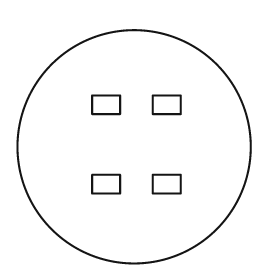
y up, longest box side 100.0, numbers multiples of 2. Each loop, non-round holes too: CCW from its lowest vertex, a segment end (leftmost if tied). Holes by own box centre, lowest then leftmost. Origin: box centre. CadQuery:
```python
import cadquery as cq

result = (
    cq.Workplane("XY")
    .moveTo(0.0, 0.0)
    .circle(50.0)
    .moveTo(-18.0, -20.0)
    .lineTo(-6.0, -20.0)
    .lineTo(-6.0, -12.0)
    .lineTo(-18.0, -12.0)
    .close()
    .moveTo(8.0, -20.0)
    .lineTo(20.0, -20.0)
    .lineTo(20.0, -12.0)
    .lineTo(8.0, -12.0)
    .close()
    .moveTo(-18.0, 14.0)
    .lineTo(-6.0, 14.0)
    .lineTo(-6.0, 22.0)
    .lineTo(-18.0, 22.0)
    .close()
    .moveTo(8.0, 14.0)
    .lineTo(20.0, 14.0)
    .lineTo(20.0, 22.0)
    .lineTo(8.0, 22.0)
    .close()
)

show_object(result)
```